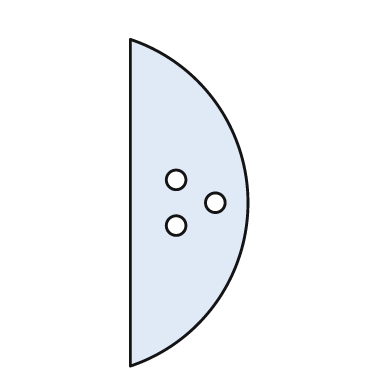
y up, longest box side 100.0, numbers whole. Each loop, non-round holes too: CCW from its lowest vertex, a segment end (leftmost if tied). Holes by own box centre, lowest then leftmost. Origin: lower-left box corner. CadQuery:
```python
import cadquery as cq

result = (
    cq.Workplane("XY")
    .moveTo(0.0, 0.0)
    .threePointArc((36.0, 50.0), (0.0, 100.0))
    .close()
    .moveTo(14.0, 43.0)
    .circle(3.0)
    .moveTo(26.0, 50.0)
    .circle(3.0)
    .moveTo(14.0, 57.0)
    .circle(3.0)
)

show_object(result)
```